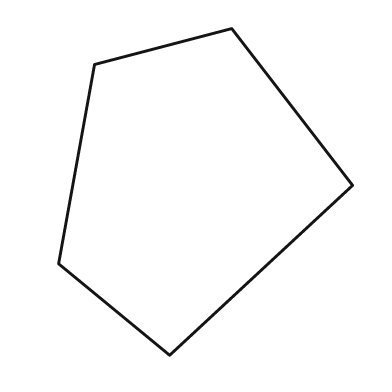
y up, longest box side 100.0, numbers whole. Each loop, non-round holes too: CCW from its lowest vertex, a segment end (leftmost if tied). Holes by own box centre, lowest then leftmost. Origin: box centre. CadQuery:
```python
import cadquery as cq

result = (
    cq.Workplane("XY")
    .moveTo(-11.0, -50.0)
    .lineTo(45.0, 2.0)
    .lineTo(8.0, 50.0)
    .lineTo(-34.0, 39.0)
    .lineTo(-45.0, -22.0)
    .close()
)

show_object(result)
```